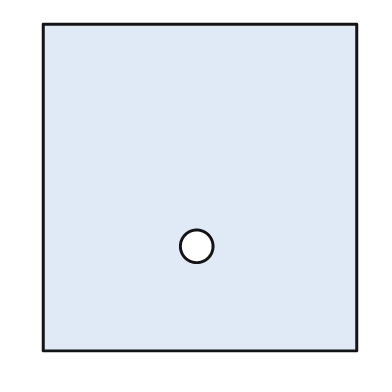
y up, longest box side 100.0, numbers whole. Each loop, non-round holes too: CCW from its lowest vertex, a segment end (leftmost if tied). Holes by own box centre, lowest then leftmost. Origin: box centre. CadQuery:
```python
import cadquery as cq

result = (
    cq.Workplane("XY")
    .moveTo(-48.0, -50.0)
    .lineTo(48.0, -50.0)
    .lineTo(48.0, 50.0)
    .lineTo(-48.0, 50.0)
    .close()
    .moveTo(-1.0, -18.0)
    .circle(5.0)
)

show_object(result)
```